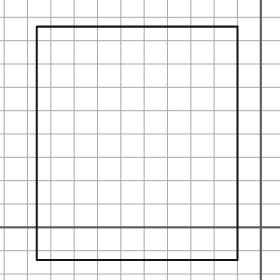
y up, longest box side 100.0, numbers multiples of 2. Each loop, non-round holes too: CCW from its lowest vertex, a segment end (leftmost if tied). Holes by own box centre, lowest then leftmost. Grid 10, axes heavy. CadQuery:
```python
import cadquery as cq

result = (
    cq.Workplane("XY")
    .moveTo(-96.0, -14.0)
    .lineTo(-10.0, -14.0)
    .lineTo(-10.0, 86.0)
    .lineTo(-96.0, 86.0)
    .close()
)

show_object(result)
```